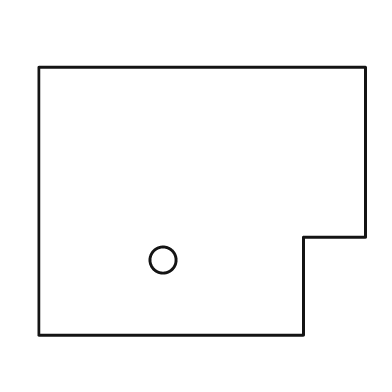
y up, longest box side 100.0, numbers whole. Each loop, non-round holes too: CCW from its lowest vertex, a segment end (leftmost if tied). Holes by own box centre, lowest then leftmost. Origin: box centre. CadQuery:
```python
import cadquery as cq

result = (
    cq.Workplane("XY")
    .moveTo(-50.0, -41.0)
    .lineTo(31.0, -41.0)
    .lineTo(31.0, -11.0)
    .lineTo(50.0, -11.0)
    .lineTo(50.0, 41.0)
    .lineTo(-50.0, 41.0)
    .close()
    .moveTo(-12.0, -18.0)
    .circle(4.0)
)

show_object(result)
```